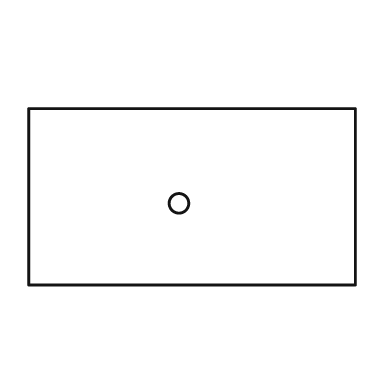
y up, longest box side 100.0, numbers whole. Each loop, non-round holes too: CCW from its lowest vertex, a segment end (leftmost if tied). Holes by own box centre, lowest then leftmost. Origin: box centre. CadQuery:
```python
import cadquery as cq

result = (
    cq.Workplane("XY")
    .moveTo(-50.0, -27.0)
    .lineTo(50.0, -27.0)
    .lineTo(50.0, 27.0)
    .lineTo(-50.0, 27.0)
    .close()
    .moveTo(-4.0, -2.0)
    .circle(3.0)
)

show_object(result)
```